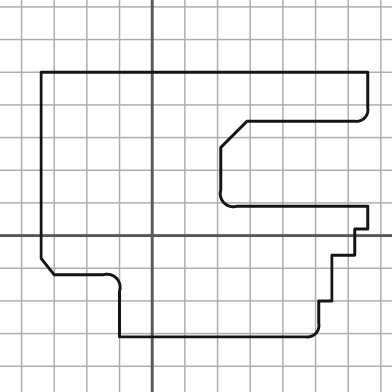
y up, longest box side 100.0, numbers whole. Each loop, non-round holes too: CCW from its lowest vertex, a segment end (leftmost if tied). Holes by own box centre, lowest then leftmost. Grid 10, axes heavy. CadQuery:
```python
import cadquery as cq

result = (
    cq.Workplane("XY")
    .moveTo(-10.0, -31.0)
    .lineTo(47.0, -31.0)
    .threePointArc((50.0, -30.0), (51.0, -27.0))
    .lineTo(51.0, -20.0)
    .lineTo(55.0, -20.0)
    .lineTo(55.0, -6.0)
    .lineTo(62.0, -6.0)
    .lineTo(62.0, 2.0)
    .lineTo(66.0, 2.0)
    .lineTo(66.0, 9.0)
    .lineTo(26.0, 9.0)
    .threePointArc((22.0, 10.0), (21.0, 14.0))
    .lineTo(21.0, 27.0)
    .lineTo(29.0, 35.0)
    .lineTo(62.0, 35.0)
    .threePointArc((65.0, 36.0), (66.0, 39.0))
    .lineTo(66.0, 50.0)
    .lineTo(-34.0, 50.0)
    .lineTo(-34.0, -7.0)
    .lineTo(-30.0, -12.0)
    .lineTo(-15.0, -12.0)
    .threePointArc((-11.0, -13.0), (-10.0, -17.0))
    .close()
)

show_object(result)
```